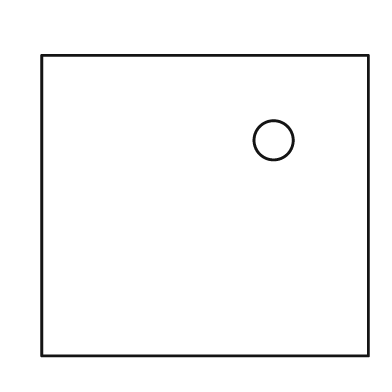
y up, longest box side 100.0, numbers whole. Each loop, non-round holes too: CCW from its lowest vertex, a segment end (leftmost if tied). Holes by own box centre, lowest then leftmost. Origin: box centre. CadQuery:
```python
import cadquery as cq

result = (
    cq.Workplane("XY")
    .moveTo(-50.0, -46.0)
    .lineTo(50.0, -46.0)
    .lineTo(50.0, 46.0)
    .lineTo(-50.0, 46.0)
    .close()
    .moveTo(21.0, 20.0)
    .circle(6.0)
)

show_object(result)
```